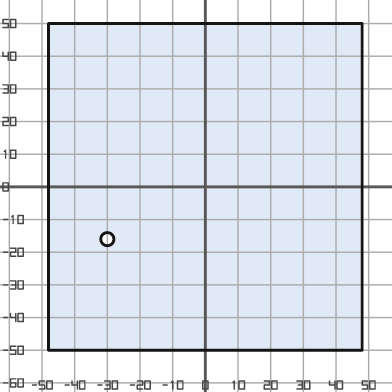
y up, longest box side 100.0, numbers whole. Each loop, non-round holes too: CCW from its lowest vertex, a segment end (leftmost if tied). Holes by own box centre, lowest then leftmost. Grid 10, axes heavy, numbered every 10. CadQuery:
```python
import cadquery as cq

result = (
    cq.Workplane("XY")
    .moveTo(-48.0, -50.0)
    .lineTo(48.0, -50.0)
    .lineTo(48.0, 50.0)
    .lineTo(-48.0, 50.0)
    .close()
    .moveTo(-30.0, -16.0)
    .circle(2.0)
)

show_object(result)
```